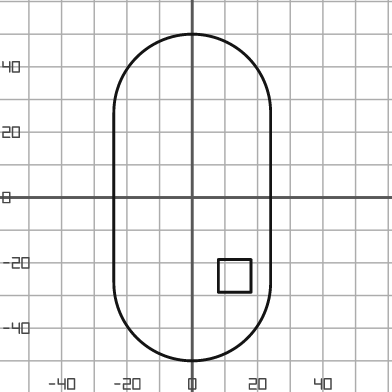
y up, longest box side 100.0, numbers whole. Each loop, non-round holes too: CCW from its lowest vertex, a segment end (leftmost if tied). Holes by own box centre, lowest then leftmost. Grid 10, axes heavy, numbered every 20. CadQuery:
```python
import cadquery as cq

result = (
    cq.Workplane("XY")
    .moveTo(-24.0, -26.0)
    .threePointArc((0.0, -50.0), (24.0, -26.0))
    .lineTo(24.0, 26.0)
    .threePointArc((0.0, 50.0), (-24.0, 26.0))
    .close()
    .moveTo(8.0, -29.0)
    .lineTo(18.0, -29.0)
    .lineTo(18.0, -19.0)
    .lineTo(8.0, -19.0)
    .close()
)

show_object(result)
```